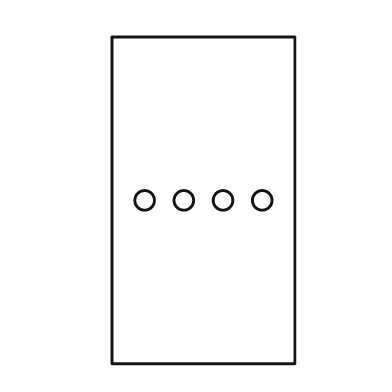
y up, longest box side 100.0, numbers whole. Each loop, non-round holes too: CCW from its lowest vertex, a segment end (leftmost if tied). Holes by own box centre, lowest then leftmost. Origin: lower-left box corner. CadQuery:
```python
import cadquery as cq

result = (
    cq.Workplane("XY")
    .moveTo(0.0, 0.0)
    .lineTo(56.0, 0.0)
    .lineTo(56.0, 100.0)
    .lineTo(0.0, 100.0)
    .close()
    .moveTo(10.0, 50.0)
    .circle(3.0)
    .moveTo(22.0, 50.0)
    .circle(3.0)
    .moveTo(34.0, 50.0)
    .circle(3.0)
    .moveTo(46.0, 50.0)
    .circle(3.0)
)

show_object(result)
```